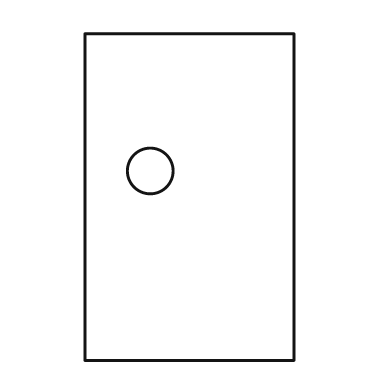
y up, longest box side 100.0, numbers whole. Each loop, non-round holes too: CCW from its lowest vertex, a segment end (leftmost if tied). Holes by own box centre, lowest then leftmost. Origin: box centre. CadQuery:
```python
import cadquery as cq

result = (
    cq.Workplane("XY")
    .moveTo(-32.0, -50.0)
    .lineTo(32.0, -50.0)
    .lineTo(32.0, 50.0)
    .lineTo(-32.0, 50.0)
    .close()
    .moveTo(-12.0, 8.0)
    .circle(7.0)
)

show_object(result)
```